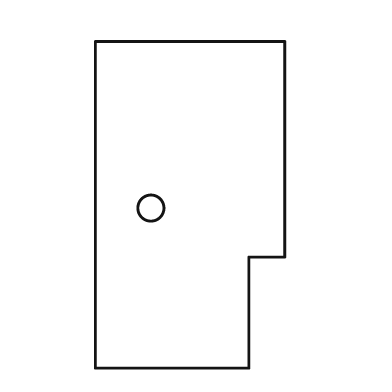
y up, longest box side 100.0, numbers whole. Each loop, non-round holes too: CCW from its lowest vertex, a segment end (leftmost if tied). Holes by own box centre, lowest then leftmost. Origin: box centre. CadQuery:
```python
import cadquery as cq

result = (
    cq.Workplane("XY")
    .moveTo(-29.0, -50.0)
    .lineTo(18.0, -50.0)
    .lineTo(18.0, -16.0)
    .lineTo(29.0, -16.0)
    .lineTo(29.0, 50.0)
    .lineTo(-29.0, 50.0)
    .close()
    .moveTo(-12.0, -1.0)
    .circle(4.0)
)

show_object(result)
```